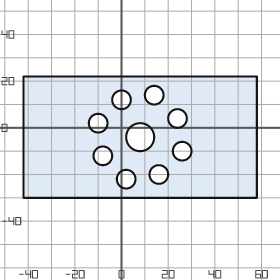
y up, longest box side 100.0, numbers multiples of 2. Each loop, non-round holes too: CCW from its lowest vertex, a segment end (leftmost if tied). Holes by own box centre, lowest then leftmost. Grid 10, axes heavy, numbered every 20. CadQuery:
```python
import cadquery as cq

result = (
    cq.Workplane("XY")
    .moveTo(-42.0, -30.0)
    .lineTo(58.0, -30.0)
    .lineTo(58.0, 22.0)
    .lineTo(-42.0, 22.0)
    .close()
    .moveTo(2.0, -22.0)
    .circle(4.0)
    .moveTo(16.0, -20.0)
    .circle(4.0)
    .moveTo(-8.0, -12.0)
    .circle(4.0)
    .moveTo(26.0, -10.0)
    .circle(4.0)
    .moveTo(8.0, -4.0)
    .circle(6.0)
    .moveTo(-10.0, 2.0)
    .circle(4.0)
    .moveTo(24.0, 4.0)
    .circle(4.0)
    .moveTo(0.0, 12.0)
    .circle(4.0)
    .moveTo(14.0, 14.0)
    .circle(4.0)
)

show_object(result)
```